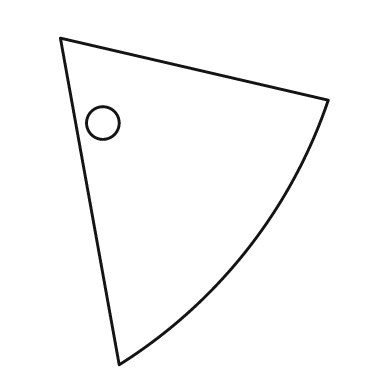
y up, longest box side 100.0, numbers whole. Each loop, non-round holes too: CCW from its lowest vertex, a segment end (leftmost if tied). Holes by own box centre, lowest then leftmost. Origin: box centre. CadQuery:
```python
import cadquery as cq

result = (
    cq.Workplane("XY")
    .moveTo(-23.0, -50.0)
    .threePointArc((16.0, -15.0), (41.0, 31.0))
    .lineTo(-41.0, 50.0)
    .close()
    .moveTo(-28.0, 24.0)
    .circle(5.0)
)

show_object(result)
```